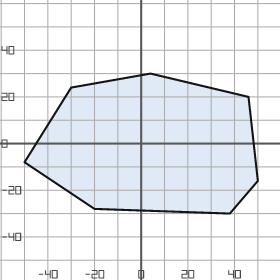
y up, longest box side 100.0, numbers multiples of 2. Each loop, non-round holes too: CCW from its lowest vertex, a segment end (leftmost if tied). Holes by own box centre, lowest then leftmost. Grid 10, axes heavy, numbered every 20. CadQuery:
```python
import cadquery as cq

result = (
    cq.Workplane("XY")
    .moveTo(38.0, -30.0)
    .lineTo(50.0, -16.0)
    .lineTo(46.0, 20.0)
    .lineTo(4.0, 30.0)
    .lineTo(-30.0, 24.0)
    .lineTo(-50.0, -8.0)
    .lineTo(-20.0, -28.0)
    .close()
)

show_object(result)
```